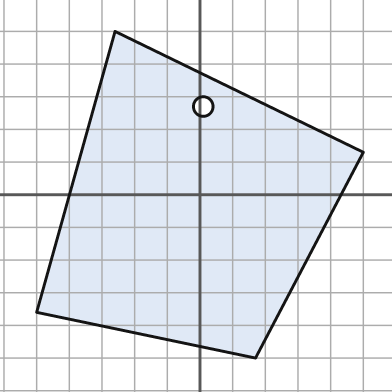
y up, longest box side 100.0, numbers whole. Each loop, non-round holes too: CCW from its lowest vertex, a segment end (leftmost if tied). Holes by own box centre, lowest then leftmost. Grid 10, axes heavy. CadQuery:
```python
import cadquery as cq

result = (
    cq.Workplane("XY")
    .moveTo(17.0, -50.0)
    .lineTo(50.0, 13.0)
    .lineTo(-26.0, 50.0)
    .lineTo(-50.0, -36.0)
    .close()
    .moveTo(1.0, 27.0)
    .circle(3.0)
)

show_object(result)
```